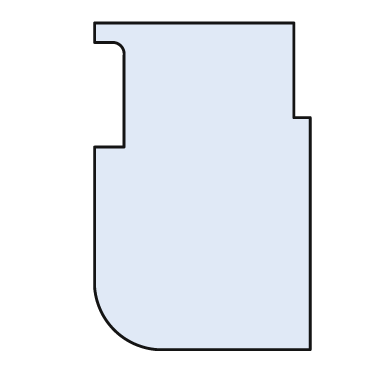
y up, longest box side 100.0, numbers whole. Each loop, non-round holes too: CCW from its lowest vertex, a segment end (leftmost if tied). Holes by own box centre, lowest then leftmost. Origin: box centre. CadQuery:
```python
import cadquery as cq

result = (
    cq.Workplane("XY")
    .moveTo(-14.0, -50.0)
    .lineTo(33.0, -50.0)
    .lineTo(33.0, 21.0)
    .lineTo(28.0, 21.0)
    .lineTo(28.0, 50.0)
    .lineTo(-33.0, 50.0)
    .lineTo(-33.0, 44.0)
    .lineTo(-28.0, 44.0)
    .threePointArc((-25.0, 43.0), (-24.0, 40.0))
    .lineTo(-24.0, 12.0)
    .lineTo(-33.0, 12.0)
    .lineTo(-33.0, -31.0)
    .threePointArc((-27.0, -44.0), (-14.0, -50.0))
    .close()
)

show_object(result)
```